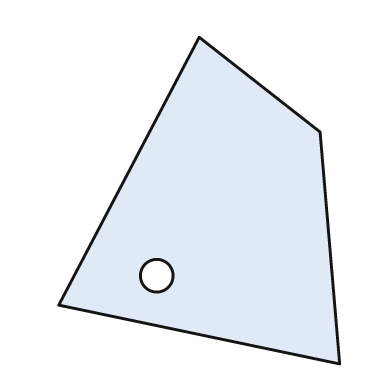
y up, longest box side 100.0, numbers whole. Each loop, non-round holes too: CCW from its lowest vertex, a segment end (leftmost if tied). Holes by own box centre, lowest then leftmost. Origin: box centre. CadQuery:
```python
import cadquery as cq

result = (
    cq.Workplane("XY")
    .moveTo(43.0, -50.0)
    .lineTo(37.0, 21.0)
    .lineTo(0.0, 50.0)
    .lineTo(-43.0, -32.0)
    .close()
    .moveTo(-13.0, -23.0)
    .circle(5.0)
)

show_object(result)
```